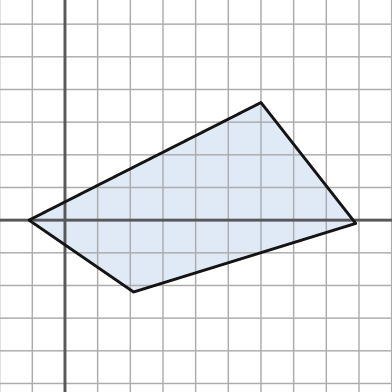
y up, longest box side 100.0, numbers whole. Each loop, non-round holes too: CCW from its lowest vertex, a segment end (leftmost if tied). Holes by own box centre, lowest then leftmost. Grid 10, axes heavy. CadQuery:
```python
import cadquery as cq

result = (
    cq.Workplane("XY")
    .moveTo(21.0, -22.0)
    .lineTo(89.0, -1.0)
    .lineTo(60.0, 36.0)
    .lineTo(-11.0, 0.0)
    .close()
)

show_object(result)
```